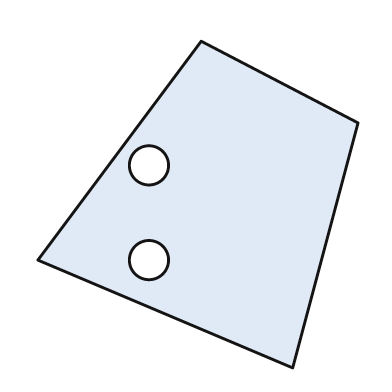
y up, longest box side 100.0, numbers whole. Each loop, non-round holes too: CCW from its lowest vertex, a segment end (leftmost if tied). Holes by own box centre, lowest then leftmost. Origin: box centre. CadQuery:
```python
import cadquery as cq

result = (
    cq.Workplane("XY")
    .moveTo(29.0, -50.0)
    .lineTo(49.0, 25.0)
    .lineTo(1.0, 50.0)
    .lineTo(-49.0, -17.0)
    .close()
    .moveTo(-15.0, -17.0)
    .circle(6.0)
    .moveTo(-15.0, 12.0)
    .circle(6.0)
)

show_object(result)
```